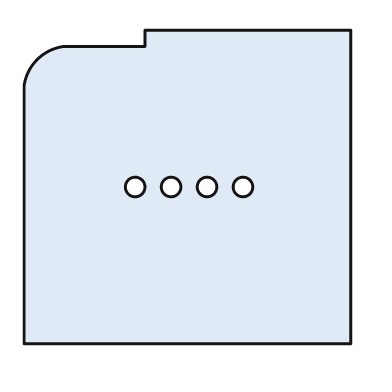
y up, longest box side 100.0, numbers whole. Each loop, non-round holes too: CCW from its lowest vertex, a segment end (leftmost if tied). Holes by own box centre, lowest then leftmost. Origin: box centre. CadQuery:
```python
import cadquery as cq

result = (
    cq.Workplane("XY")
    .moveTo(-50.0, -48.0)
    .lineTo(50.0, -48.0)
    .lineTo(50.0, 48.0)
    .lineTo(-13.0, 48.0)
    .lineTo(-13.0, 43.0)
    .lineTo(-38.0, 43.0)
    .threePointArc((-46.0, 39.0), (-50.0, 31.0))
    .close()
    .moveTo(-16.0, 0.0)
    .circle(3.0)
    .moveTo(-5.0, 0.0)
    .circle(3.0)
    .moveTo(6.0, 0.0)
    .circle(3.0)
    .moveTo(17.0, 0.0)
    .circle(3.0)
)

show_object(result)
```